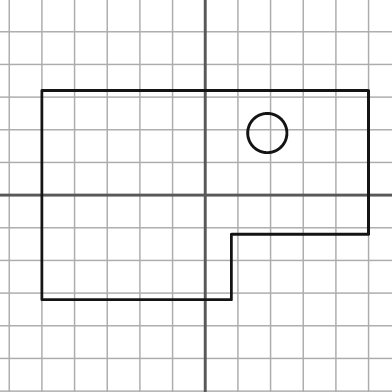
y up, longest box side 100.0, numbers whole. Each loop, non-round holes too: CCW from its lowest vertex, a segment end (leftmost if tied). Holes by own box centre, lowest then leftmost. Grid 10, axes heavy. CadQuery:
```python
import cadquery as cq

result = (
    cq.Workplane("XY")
    .moveTo(-50.0, -32.0)
    .lineTo(8.0, -32.0)
    .lineTo(8.0, -12.0)
    .lineTo(50.0, -12.0)
    .lineTo(50.0, 32.0)
    .lineTo(-50.0, 32.0)
    .close()
    .moveTo(19.0, 19.0)
    .circle(6.0)
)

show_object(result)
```